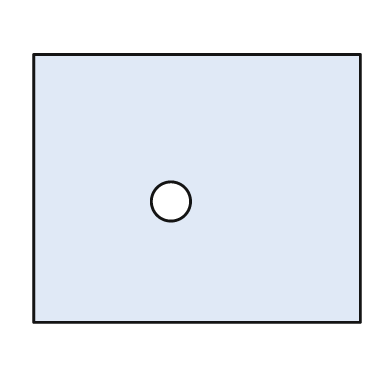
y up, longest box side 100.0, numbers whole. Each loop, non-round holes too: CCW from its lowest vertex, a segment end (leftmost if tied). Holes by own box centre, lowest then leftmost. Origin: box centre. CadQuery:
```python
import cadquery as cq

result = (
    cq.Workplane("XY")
    .moveTo(-50.0, -41.0)
    .lineTo(50.0, -41.0)
    .lineTo(50.0, 41.0)
    .lineTo(-50.0, 41.0)
    .close()
    .moveTo(-8.0, -4.0)
    .circle(6.0)
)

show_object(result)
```